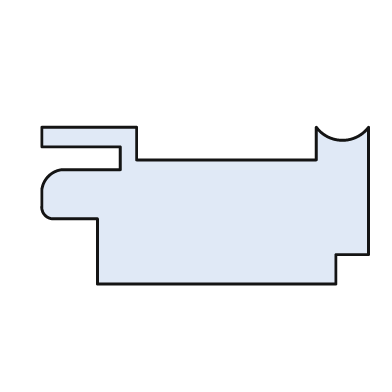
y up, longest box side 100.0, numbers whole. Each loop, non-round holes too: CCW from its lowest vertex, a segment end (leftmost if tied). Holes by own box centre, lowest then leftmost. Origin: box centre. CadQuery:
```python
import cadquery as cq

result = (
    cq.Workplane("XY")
    .moveTo(-33.0, -24.0)
    .lineTo(40.0, -24.0)
    .lineTo(40.0, -15.0)
    .lineTo(50.0, -15.0)
    .lineTo(50.0, 24.0)
    .threePointArc((42.0, 20.0), (34.0, 24.0))
    .lineTo(34.0, 14.0)
    .lineTo(-21.0, 14.0)
    .lineTo(-21.0, 24.0)
    .lineTo(-50.0, 24.0)
    .lineTo(-50.0, 18.0)
    .lineTo(-26.0, 18.0)
    .lineTo(-26.0, 11.0)
    .lineTo(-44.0, 11.0)
    .threePointArc((-48.0, 9.0), (-50.0, 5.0))
    .lineTo(-50.0, 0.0)
    .threePointArc((-49.0, -3.0), (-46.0, -4.0))
    .lineTo(-33.0, -4.0)
    .close()
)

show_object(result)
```